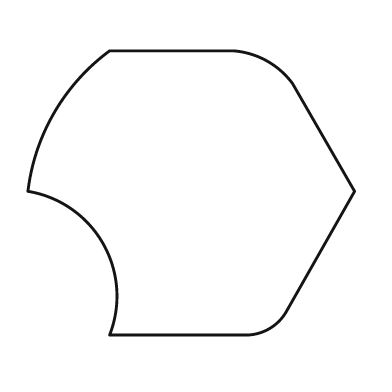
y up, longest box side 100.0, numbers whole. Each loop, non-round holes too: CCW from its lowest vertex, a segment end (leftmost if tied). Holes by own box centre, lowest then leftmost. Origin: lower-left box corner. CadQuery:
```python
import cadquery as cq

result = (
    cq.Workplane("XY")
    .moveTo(25.0, 0.0)
    .lineTo(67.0, 0.0)
    .threePointArc((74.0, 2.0), (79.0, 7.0))
    .lineTo(100.0, 44.0)
    .lineTo(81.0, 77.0)
    .threePointArc((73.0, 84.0), (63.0, 87.0))
    .lineTo(25.0, 87.0)
    .threePointArc((8.0, 68.0), (0.0, 44.0))
    .threePointArc((23.0, 28.0), (25.0, 0.0))
    .close()
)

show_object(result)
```